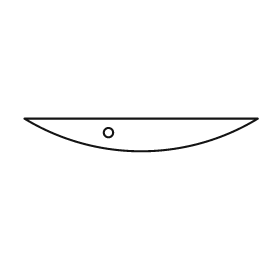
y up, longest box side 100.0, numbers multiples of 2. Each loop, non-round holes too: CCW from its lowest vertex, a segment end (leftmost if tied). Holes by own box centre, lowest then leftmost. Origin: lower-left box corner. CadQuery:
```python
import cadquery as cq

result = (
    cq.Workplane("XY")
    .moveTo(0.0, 14.0)
    .threePointArc((50.0, 0.0), (100.0, 14.0))
    .close()
    .moveTo(36.0, 8.0)
    .circle(2.0)
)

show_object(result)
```